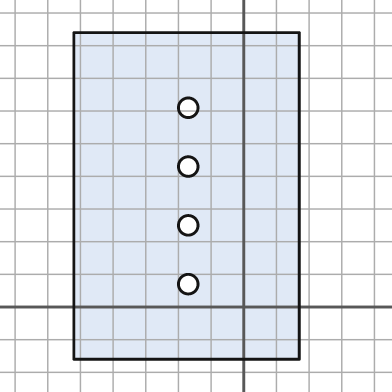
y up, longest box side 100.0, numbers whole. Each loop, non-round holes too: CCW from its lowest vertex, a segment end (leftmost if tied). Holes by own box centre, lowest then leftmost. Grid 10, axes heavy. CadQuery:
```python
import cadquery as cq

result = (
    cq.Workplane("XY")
    .moveTo(-52.0, -16.0)
    .lineTo(17.0, -16.0)
    .lineTo(17.0, 84.0)
    .lineTo(-52.0, 84.0)
    .close()
    .moveTo(-17.0, 7.0)
    .circle(3.0)
    .moveTo(-17.0, 25.0)
    .circle(3.0)
    .moveTo(-17.0, 43.0)
    .circle(3.0)
    .moveTo(-17.0, 61.0)
    .circle(3.0)
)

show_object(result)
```